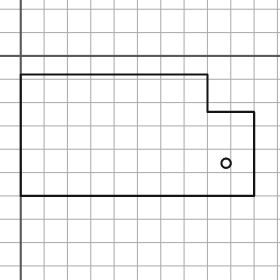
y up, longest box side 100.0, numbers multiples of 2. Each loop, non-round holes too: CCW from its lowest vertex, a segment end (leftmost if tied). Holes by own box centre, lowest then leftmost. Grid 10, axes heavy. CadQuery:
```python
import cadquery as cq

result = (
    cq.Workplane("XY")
    .moveTo(0.0, -60.0)
    .lineTo(100.0, -60.0)
    .lineTo(100.0, -24.0)
    .lineTo(80.0, -24.0)
    .lineTo(80.0, -8.0)
    .lineTo(0.0, -8.0)
    .close()
    .moveTo(88.0, -46.0)
    .circle(2.0)
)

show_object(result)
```